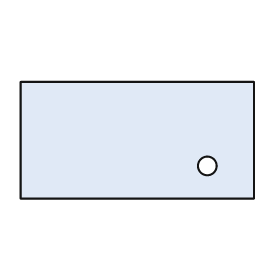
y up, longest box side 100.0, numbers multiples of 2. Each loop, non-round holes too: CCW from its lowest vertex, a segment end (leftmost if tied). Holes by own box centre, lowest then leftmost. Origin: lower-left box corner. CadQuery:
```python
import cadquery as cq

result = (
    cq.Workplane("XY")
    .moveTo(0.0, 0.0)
    .lineTo(100.0, 0.0)
    .lineTo(100.0, 50.0)
    .lineTo(0.0, 50.0)
    .close()
    .moveTo(80.0, 14.0)
    .circle(4.0)
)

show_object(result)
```